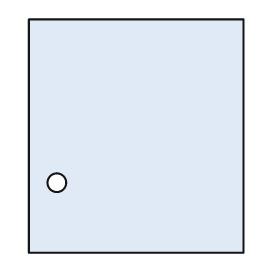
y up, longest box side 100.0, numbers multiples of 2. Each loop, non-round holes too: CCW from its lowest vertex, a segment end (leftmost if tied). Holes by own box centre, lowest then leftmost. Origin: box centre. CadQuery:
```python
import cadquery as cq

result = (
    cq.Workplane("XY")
    .moveTo(-46.0, -50.0)
    .lineTo(46.0, -50.0)
    .lineTo(46.0, 50.0)
    .lineTo(-46.0, 50.0)
    .close()
    .moveTo(-34.0, -20.0)
    .circle(4.0)
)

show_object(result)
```